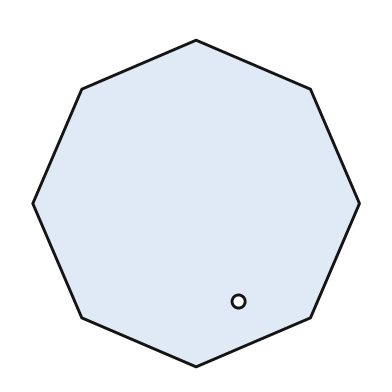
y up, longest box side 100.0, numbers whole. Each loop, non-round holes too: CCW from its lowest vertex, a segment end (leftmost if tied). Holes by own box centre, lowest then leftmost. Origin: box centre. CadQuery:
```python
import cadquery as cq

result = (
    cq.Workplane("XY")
    .moveTo(0.0, -50.0)
    .lineTo(35.0, -35.0)
    .lineTo(50.0, 0.0)
    .lineTo(35.0, 35.0)
    .lineTo(0.0, 50.0)
    .lineTo(-35.0, 35.0)
    .lineTo(-50.0, 0.0)
    .lineTo(-35.0, -35.0)
    .close()
    .moveTo(13.0, -30.0)
    .circle(2.0)
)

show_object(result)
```